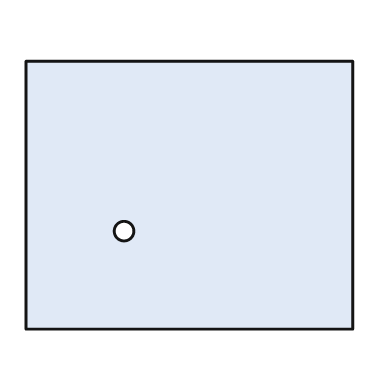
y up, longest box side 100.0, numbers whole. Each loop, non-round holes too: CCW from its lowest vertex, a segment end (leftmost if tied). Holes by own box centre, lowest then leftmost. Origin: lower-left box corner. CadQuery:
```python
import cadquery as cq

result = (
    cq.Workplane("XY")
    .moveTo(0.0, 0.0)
    .lineTo(100.0, 0.0)
    .lineTo(100.0, 82.0)
    .lineTo(0.0, 82.0)
    .close()
    .moveTo(30.0, 30.0)
    .circle(3.0)
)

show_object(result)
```